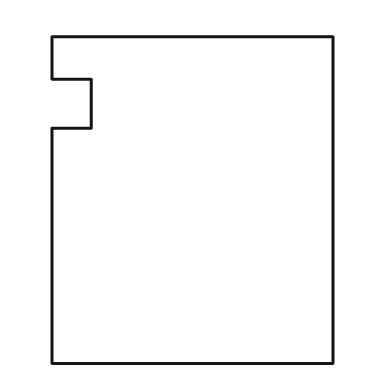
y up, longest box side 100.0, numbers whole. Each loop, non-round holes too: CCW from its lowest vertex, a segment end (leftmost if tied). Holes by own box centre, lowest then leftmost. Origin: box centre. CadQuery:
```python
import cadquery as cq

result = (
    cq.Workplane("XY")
    .moveTo(-43.0, -50.0)
    .lineTo(43.0, -50.0)
    .lineTo(43.0, 50.0)
    .lineTo(-43.0, 50.0)
    .lineTo(-43.0, 37.0)
    .lineTo(-31.0, 37.0)
    .lineTo(-31.0, 22.0)
    .lineTo(-43.0, 22.0)
    .close()
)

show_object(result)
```